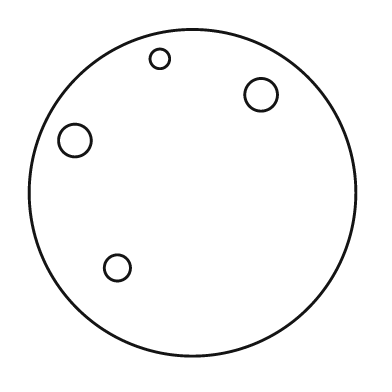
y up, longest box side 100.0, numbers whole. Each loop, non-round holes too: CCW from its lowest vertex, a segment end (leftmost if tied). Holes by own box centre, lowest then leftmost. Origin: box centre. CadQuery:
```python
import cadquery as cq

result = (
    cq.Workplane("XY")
    .moveTo(0.0, 0.0)
    .circle(50.0)
    .moveTo(-23.0, -23.0)
    .circle(4.0)
    .moveTo(-36.0, 16.0)
    .circle(5.0)
    .moveTo(21.0, 30.0)
    .circle(5.0)
    .moveTo(-10.0, 41.0)
    .circle(3.0)
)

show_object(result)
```